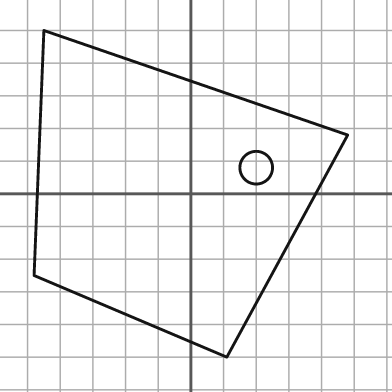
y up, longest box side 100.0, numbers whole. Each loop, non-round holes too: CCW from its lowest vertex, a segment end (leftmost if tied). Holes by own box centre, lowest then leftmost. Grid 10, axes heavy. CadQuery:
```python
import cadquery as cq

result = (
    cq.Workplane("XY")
    .moveTo(11.0, -50.0)
    .lineTo(48.0, 18.0)
    .lineTo(-45.0, 50.0)
    .lineTo(-48.0, -25.0)
    .close()
    .moveTo(20.0, 8.0)
    .circle(5.0)
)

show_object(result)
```